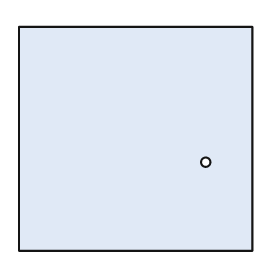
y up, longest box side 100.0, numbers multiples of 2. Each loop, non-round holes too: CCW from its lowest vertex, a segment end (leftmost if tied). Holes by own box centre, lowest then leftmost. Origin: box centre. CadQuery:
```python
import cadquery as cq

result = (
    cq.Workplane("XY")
    .moveTo(-50.0, -48.0)
    .lineTo(50.0, -48.0)
    .lineTo(50.0, 48.0)
    .lineTo(-50.0, 48.0)
    .close()
    .moveTo(30.0, -10.0)
    .circle(2.0)
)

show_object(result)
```